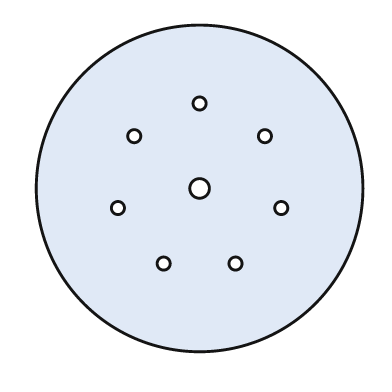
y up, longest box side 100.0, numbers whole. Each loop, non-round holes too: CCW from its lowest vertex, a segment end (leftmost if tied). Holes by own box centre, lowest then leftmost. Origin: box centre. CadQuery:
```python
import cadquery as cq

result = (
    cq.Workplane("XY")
    .moveTo(0.0, 0.0)
    .circle(50.0)
    .moveTo(-11.0, -23.0)
    .circle(2.0)
    .moveTo(11.0, -23.0)
    .circle(2.0)
    .moveTo(-25.0, -6.0)
    .circle(2.0)
    .moveTo(25.0, -6.0)
    .circle(2.0)
    .moveTo(0.0, 0.0)
    .circle(3.0)
    .moveTo(-20.0, 16.0)
    .circle(2.0)
    .moveTo(20.0, 16.0)
    .circle(2.0)
    .moveTo(0.0, 26.0)
    .circle(2.0)
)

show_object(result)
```